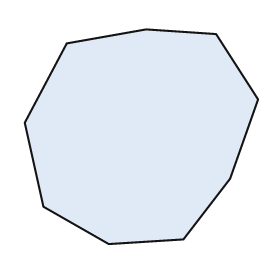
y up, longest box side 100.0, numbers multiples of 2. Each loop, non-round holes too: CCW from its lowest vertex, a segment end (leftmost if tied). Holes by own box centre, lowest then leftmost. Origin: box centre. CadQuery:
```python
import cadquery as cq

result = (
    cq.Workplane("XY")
    .moveTo(-14.0, -46.0)
    .lineTo(18.0, -44.0)
    .lineTo(38.0, -18.0)
    .lineTo(50.0, 16.0)
    .lineTo(32.0, 44.0)
    .lineTo(2.0, 46.0)
    .lineTo(-32.0, 40.0)
    .lineTo(-50.0, 6.0)
    .lineTo(-42.0, -30.0)
    .close()
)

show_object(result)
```